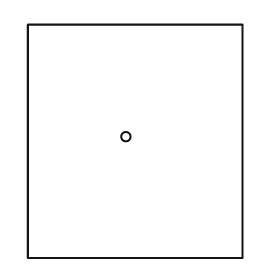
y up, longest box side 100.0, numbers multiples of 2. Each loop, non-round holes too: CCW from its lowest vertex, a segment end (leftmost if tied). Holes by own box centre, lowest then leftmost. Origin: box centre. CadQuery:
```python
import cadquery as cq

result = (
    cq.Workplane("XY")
    .moveTo(-46.0, -50.0)
    .lineTo(46.0, -50.0)
    .lineTo(46.0, 50.0)
    .lineTo(-46.0, 50.0)
    .close()
    .moveTo(-4.0, 2.0)
    .circle(2.0)
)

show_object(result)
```